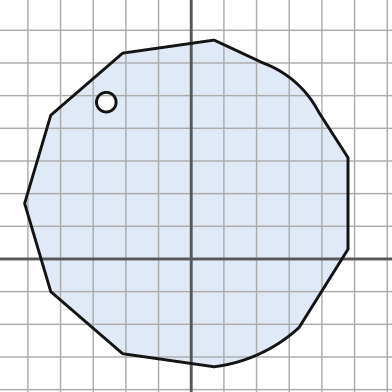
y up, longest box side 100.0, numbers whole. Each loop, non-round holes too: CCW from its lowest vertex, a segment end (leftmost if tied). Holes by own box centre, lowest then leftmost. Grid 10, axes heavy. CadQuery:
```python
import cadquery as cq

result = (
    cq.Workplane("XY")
    .moveTo(7.0, -33.0)
    .threePointArc((21.0, -29.0), (33.0, -21.0))
    .lineTo(48.0, 3.0)
    .lineTo(48.0, 31.0)
    .lineTo(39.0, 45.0)
    .threePointArc((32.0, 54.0), (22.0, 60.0))
    .lineTo(7.0, 67.0)
    .lineTo(-21.0, 63.0)
    .lineTo(-43.0, 44.0)
    .lineTo(-51.0, 17.0)
    .lineTo(-43.0, -10.0)
    .lineTo(-21.0, -29.0)
    .close()
    .moveTo(-26.0, 48.0)
    .circle(3.0)
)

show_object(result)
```